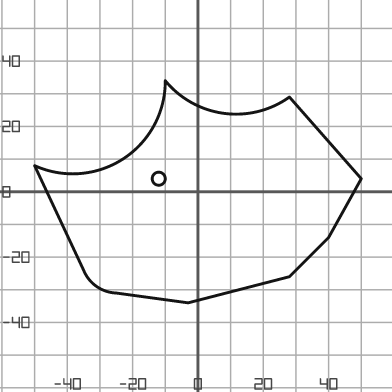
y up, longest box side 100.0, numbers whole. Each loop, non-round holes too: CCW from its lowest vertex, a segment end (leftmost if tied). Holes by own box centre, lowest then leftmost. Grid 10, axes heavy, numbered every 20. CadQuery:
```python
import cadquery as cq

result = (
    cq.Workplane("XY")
    .moveTo(-3.0, -34.0)
    .lineTo(28.0, -26.0)
    .lineTo(40.0, -14.0)
    .lineTo(50.0, 4.0)
    .lineTo(28.0, 29.0)
    .threePointArc((8.0, 24.0), (-10.0, 34.0))
    .threePointArc((-23.0, 10.0), (-50.0, 8.0))
    .lineTo(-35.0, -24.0)
    .threePointArc((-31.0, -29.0), (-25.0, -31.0))
    .close()
    .moveTo(-12.0, 4.0)
    .circle(2.0)
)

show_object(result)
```